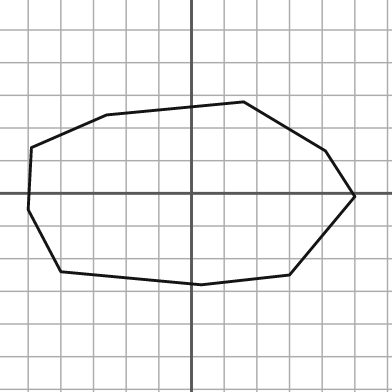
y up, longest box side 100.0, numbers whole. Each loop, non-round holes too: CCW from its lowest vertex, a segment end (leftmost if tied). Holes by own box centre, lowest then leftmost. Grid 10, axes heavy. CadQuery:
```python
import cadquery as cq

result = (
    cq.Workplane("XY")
    .moveTo(3.0, -28.0)
    .lineTo(30.0, -25.0)
    .lineTo(50.0, -1.0)
    .lineTo(41.0, 13.0)
    .lineTo(16.0, 28.0)
    .lineTo(-26.0, 24.0)
    .lineTo(-49.0, 14.0)
    .lineTo(-50.0, -5.0)
    .lineTo(-40.0, -24.0)
    .close()
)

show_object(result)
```